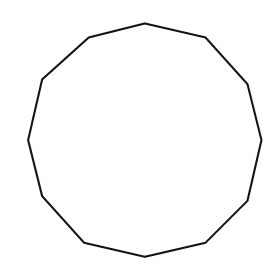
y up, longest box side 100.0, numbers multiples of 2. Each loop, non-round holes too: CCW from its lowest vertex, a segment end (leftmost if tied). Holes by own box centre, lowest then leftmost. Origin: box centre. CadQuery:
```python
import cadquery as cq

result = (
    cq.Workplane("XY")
    .moveTo(0.0, -50.0)
    .lineTo(26.0, -44.0)
    .lineTo(44.0, -26.0)
    .lineTo(50.0, 0.0)
    .lineTo(44.0, 24.0)
    .lineTo(26.0, 44.0)
    .lineTo(0.0, 50.0)
    .lineTo(-24.0, 44.0)
    .lineTo(-44.0, 26.0)
    .lineTo(-50.0, 0.0)
    .lineTo(-44.0, -24.0)
    .lineTo(-26.0, -44.0)
    .close()
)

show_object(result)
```